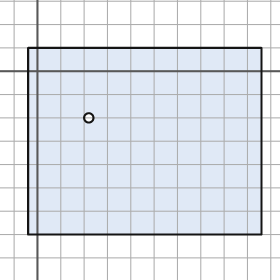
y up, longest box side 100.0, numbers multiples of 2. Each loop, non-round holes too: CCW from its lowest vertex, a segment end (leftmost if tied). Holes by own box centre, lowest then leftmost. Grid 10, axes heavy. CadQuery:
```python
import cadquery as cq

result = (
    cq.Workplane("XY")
    .moveTo(-4.0, -70.0)
    .lineTo(96.0, -70.0)
    .lineTo(96.0, 10.0)
    .lineTo(-4.0, 10.0)
    .close()
    .moveTo(22.0, -20.0)
    .circle(2.0)
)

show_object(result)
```